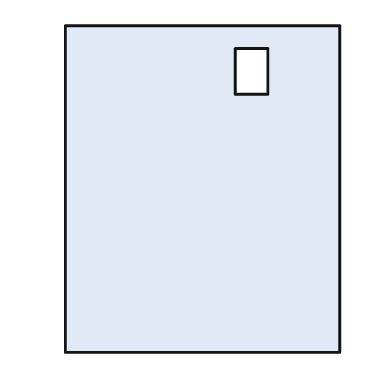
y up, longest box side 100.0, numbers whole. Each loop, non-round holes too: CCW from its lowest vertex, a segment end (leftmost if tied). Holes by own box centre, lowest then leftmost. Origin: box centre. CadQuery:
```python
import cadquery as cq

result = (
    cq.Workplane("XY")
    .moveTo(-42.0, -50.0)
    .lineTo(42.0, -50.0)
    .lineTo(42.0, 50.0)
    .lineTo(-42.0, 50.0)
    .close()
    .moveTo(10.0, 29.0)
    .lineTo(20.0, 29.0)
    .lineTo(20.0, 43.0)
    .lineTo(10.0, 43.0)
    .close()
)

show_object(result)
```